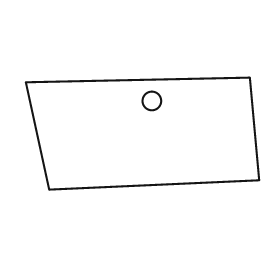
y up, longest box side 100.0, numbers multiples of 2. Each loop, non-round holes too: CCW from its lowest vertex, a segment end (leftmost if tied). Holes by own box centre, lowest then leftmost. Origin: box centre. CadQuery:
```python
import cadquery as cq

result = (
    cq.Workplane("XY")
    .moveTo(-40.0, -24.0)
    .lineTo(50.0, -20.0)
    .lineTo(46.0, 24.0)
    .lineTo(-50.0, 22.0)
    .close()
    .moveTo(4.0, 14.0)
    .circle(4.0)
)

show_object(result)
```